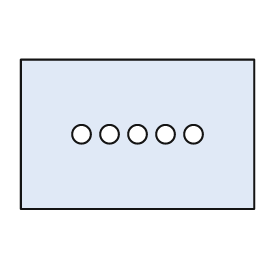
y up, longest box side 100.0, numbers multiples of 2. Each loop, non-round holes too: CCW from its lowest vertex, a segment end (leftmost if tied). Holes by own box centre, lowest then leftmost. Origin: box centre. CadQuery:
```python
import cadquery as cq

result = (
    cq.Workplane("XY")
    .moveTo(-50.0, -32.0)
    .lineTo(50.0, -32.0)
    .lineTo(50.0, 32.0)
    .lineTo(-50.0, 32.0)
    .close()
    .moveTo(-24.0, 0.0)
    .circle(4.0)
    .moveTo(-12.0, 0.0)
    .circle(4.0)
    .moveTo(0.0, 0.0)
    .circle(4.0)
    .moveTo(12.0, 0.0)
    .circle(4.0)
    .moveTo(24.0, 0.0)
    .circle(4.0)
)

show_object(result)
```